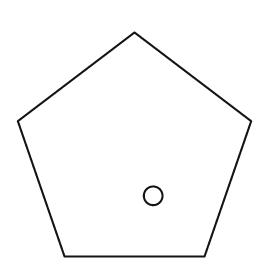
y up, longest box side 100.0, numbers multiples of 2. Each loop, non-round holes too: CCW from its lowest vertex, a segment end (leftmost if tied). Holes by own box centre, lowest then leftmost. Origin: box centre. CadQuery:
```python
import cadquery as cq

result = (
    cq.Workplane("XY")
    .moveTo(-30.0, -48.0)
    .lineTo(30.0, -48.0)
    .lineTo(50.0, 10.0)
    .lineTo(0.0, 48.0)
    .lineTo(-50.0, 10.0)
    .close()
    .moveTo(8.0, -22.0)
    .circle(4.0)
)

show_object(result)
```